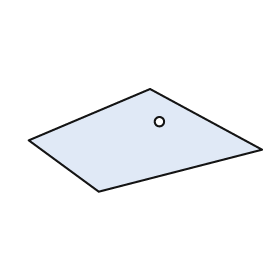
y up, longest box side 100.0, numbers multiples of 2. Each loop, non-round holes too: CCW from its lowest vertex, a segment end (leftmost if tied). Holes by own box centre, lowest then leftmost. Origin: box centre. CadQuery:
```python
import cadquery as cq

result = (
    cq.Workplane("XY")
    .moveTo(-20.0, -22.0)
    .lineTo(50.0, -4.0)
    .lineTo(2.0, 22.0)
    .lineTo(-50.0, 0.0)
    .close()
    .moveTo(6.0, 8.0)
    .circle(2.0)
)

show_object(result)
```